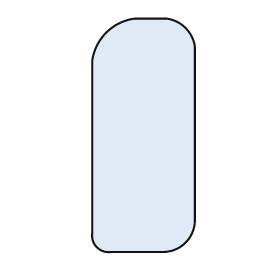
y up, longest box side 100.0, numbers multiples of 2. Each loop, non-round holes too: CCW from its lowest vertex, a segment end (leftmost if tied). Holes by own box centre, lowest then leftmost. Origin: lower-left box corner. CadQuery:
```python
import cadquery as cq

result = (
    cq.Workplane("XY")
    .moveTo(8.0, 0.0)
    .lineTo(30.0, 0.0)
    .threePointArc((40.0, 4.0), (44.0, 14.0))
    .lineTo(44.0, 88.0)
    .threePointArc((40.0, 96.0), (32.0, 100.0))
    .lineTo(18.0, 100.0)
    .threePointArc((6.0, 94.0), (0.0, 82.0))
    .lineTo(0.0, 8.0)
    .threePointArc((2.0, 2.0), (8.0, 0.0))
    .close()
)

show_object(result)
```